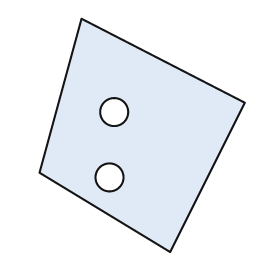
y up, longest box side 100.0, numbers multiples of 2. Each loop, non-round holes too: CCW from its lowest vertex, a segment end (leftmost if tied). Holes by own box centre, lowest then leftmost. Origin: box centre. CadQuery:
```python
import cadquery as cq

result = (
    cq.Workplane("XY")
    .moveTo(12.0, -50.0)
    .lineTo(44.0, 14.0)
    .lineTo(-26.0, 50.0)
    .lineTo(-44.0, -16.0)
    .close()
    .moveTo(-14.0, -18.0)
    .circle(6.0)
    .moveTo(-12.0, 10.0)
    .circle(6.0)
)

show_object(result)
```